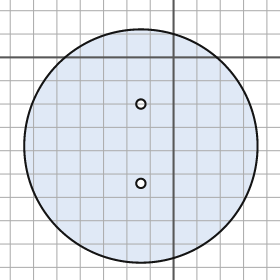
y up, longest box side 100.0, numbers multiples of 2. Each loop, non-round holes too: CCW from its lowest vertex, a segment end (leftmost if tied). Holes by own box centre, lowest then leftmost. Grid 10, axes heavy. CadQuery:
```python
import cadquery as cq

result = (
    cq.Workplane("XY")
    .moveTo(-14.0, -38.0)
    .circle(50.0)
    .moveTo(-14.0, -54.0)
    .circle(2.0)
    .moveTo(-14.0, -20.0)
    .circle(2.0)
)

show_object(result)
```